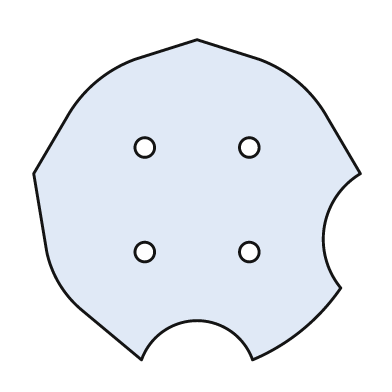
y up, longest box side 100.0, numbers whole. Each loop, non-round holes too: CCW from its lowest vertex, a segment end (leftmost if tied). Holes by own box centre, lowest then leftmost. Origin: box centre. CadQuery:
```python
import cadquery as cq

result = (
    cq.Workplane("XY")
    .moveTo(-17.0, -49.0)
    .threePointArc((0.0, -37.0), (17.0, -49.0))
    .threePointArc((32.0, -40.0), (44.0, -27.0))
    .threePointArc((39.0, -8.0), (50.0, 8.0))
    .lineTo(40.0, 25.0)
    .threePointArc((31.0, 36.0), (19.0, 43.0))
    .lineTo(0.0, 49.0)
    .lineTo(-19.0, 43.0)
    .threePointArc((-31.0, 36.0), (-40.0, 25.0))
    .lineTo(-50.0, 8.0)
    .lineTo(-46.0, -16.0)
    .threePointArc((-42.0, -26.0), (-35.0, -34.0))
    .close()
    .moveTo(-16.0, -16.0)
    .circle(3.0)
    .moveTo(16.0, -16.0)
    .circle(3.0)
    .moveTo(-16.0, 16.0)
    .circle(3.0)
    .moveTo(16.0, 16.0)
    .circle(3.0)
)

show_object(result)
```